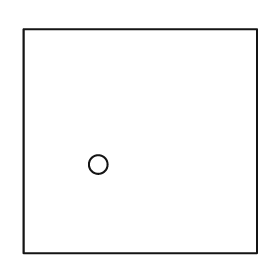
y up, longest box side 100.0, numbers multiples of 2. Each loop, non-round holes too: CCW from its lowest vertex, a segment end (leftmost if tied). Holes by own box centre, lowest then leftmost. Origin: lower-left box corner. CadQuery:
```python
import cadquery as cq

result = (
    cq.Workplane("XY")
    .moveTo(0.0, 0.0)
    .lineTo(100.0, 0.0)
    .lineTo(100.0, 96.0)
    .lineTo(0.0, 96.0)
    .close()
    .moveTo(32.0, 38.0)
    .circle(4.0)
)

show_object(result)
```